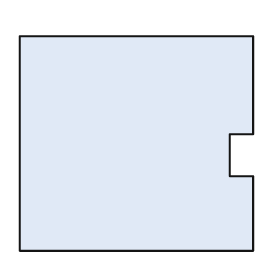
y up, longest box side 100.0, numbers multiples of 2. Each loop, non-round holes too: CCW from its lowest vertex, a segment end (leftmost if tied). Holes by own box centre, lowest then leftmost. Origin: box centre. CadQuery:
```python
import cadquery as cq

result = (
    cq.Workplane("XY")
    .moveTo(-50.0, -46.0)
    .lineTo(50.0, -46.0)
    .lineTo(50.0, -14.0)
    .lineTo(40.0, -14.0)
    .lineTo(40.0, 4.0)
    .lineTo(50.0, 4.0)
    .lineTo(50.0, 46.0)
    .lineTo(-50.0, 46.0)
    .close()
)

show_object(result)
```